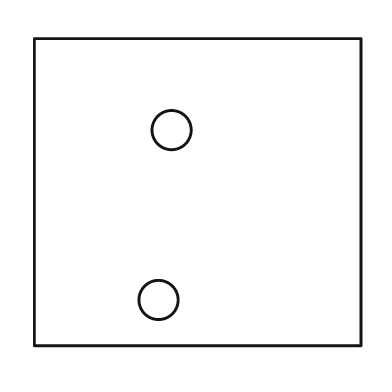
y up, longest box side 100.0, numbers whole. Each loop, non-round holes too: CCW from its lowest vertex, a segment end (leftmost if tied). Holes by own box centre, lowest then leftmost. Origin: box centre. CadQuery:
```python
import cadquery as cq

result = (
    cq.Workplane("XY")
    .moveTo(-50.0, -47.0)
    .lineTo(50.0, -47.0)
    .lineTo(50.0, 47.0)
    .lineTo(-50.0, 47.0)
    .close()
    .moveTo(-12.0, -33.0)
    .circle(6.0)
    .moveTo(-8.0, 19.0)
    .circle(6.0)
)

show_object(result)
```